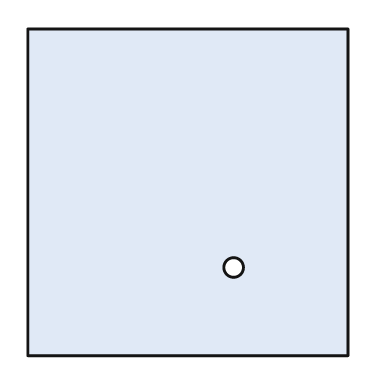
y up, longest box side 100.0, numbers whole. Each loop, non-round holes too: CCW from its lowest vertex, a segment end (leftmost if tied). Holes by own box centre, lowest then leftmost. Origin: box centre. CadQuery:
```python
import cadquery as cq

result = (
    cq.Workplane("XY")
    .moveTo(-49.0, -50.0)
    .lineTo(49.0, -50.0)
    .lineTo(49.0, 50.0)
    .lineTo(-49.0, 50.0)
    .close()
    .moveTo(14.0, -23.0)
    .circle(3.0)
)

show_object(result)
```